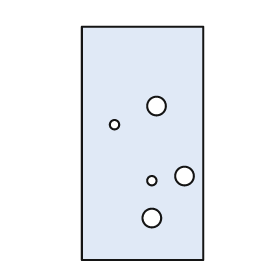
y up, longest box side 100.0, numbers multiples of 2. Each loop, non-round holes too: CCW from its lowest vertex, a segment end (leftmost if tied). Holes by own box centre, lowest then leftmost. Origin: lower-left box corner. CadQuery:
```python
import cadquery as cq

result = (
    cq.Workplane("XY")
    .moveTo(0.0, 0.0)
    .lineTo(52.0, 0.0)
    .lineTo(52.0, 100.0)
    .lineTo(0.0, 100.0)
    .close()
    .moveTo(30.0, 18.0)
    .circle(4.0)
    .moveTo(30.0, 34.0)
    .circle(2.0)
    .moveTo(44.0, 36.0)
    .circle(4.0)
    .moveTo(14.0, 58.0)
    .circle(2.0)
    .moveTo(32.0, 66.0)
    .circle(4.0)
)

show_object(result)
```